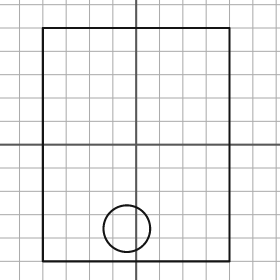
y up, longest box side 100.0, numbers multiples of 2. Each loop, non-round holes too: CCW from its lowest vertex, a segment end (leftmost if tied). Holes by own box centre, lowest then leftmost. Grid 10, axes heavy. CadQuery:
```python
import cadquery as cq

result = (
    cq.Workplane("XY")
    .moveTo(-40.0, -50.0)
    .lineTo(40.0, -50.0)
    .lineTo(40.0, 50.0)
    .lineTo(-40.0, 50.0)
    .close()
    .moveTo(-4.0, -36.0)
    .circle(10.0)
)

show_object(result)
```